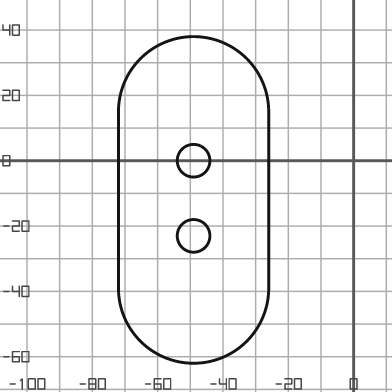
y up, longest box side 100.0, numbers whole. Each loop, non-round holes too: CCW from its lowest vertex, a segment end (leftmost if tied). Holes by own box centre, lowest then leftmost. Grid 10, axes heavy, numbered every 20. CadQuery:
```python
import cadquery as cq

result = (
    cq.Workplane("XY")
    .moveTo(-72.0, -39.0)
    .threePointArc((-49.0, -62.0), (-26.0, -39.0))
    .lineTo(-26.0, 15.0)
    .threePointArc((-49.0, 38.0), (-72.0, 15.0))
    .close()
    .moveTo(-49.0, -23.0)
    .circle(5.0)
    .moveTo(-49.0, 0.0)
    .circle(5.0)
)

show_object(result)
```